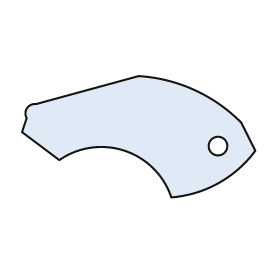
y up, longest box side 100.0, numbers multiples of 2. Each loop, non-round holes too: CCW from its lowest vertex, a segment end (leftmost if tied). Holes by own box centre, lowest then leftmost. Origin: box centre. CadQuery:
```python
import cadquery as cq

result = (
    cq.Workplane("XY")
    .moveTo(14.0, -26.0)
    .threePointArc((34.0, -20.0), (50.0, -6.0))
    .lineTo(44.0, 6.0)
    .threePointArc((24.0, 20.0), (0.0, 26.0))
    .lineTo(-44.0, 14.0)
    .threePointArc((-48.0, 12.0), (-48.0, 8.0))
    .lineTo(-50.0, 2.0)
    .lineTo(-34.0, -10.0)
    .threePointArc((-6.0, -6.0), (14.0, -26.0))
    .close()
    .moveTo(34.0, -4.0)
    .circle(4.0)
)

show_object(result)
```